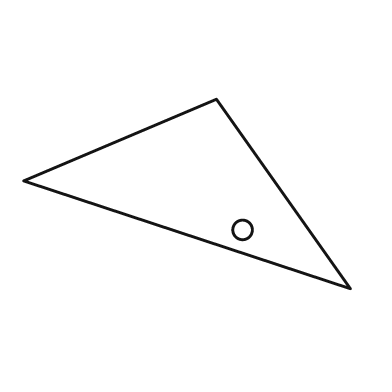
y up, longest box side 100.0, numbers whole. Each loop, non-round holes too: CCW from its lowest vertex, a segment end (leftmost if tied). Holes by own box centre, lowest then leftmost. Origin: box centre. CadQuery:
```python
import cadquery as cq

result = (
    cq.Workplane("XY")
    .moveTo(50.0, -29.0)
    .lineTo(9.0, 29.0)
    .lineTo(-50.0, 4.0)
    .close()
    .moveTo(17.0, -11.0)
    .circle(3.0)
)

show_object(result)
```